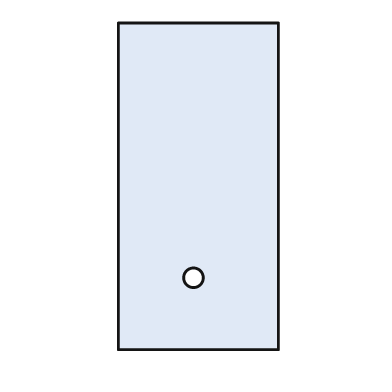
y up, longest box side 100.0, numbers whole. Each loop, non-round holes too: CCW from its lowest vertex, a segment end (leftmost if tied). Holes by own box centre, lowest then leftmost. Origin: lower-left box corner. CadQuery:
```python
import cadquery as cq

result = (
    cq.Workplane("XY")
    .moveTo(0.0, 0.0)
    .lineTo(49.0, 0.0)
    .lineTo(49.0, 100.0)
    .lineTo(0.0, 100.0)
    .close()
    .moveTo(23.0, 22.0)
    .circle(3.0)
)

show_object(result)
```